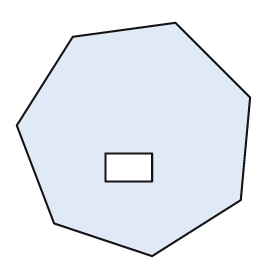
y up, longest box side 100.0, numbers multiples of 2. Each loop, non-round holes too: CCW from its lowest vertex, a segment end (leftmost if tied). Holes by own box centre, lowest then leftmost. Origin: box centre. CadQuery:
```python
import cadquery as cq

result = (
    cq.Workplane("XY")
    .moveTo(8.0, -50.0)
    .lineTo(46.0, -26.0)
    .lineTo(50.0, 18.0)
    .lineTo(18.0, 50.0)
    .lineTo(-26.0, 44.0)
    .lineTo(-50.0, 6.0)
    .lineTo(-34.0, -36.0)
    .close()
    .moveTo(-12.0, -18.0)
    .lineTo(8.0, -18.0)
    .lineTo(8.0, -6.0)
    .lineTo(-12.0, -6.0)
    .close()
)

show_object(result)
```